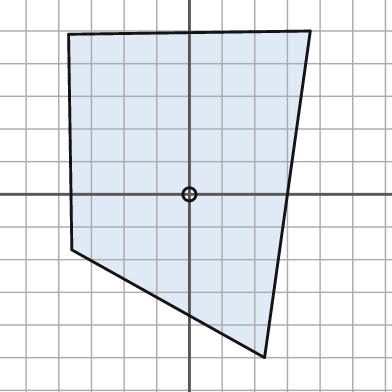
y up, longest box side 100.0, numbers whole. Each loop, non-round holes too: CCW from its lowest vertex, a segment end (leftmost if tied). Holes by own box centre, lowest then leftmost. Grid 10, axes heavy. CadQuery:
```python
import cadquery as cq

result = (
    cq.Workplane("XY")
    .moveTo(23.0, -50.0)
    .lineTo(37.0, 50.0)
    .lineTo(-37.0, 49.0)
    .lineTo(-36.0, -17.0)
    .close()
    .moveTo(0.0, 0.0)
    .circle(2.0)
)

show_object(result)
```